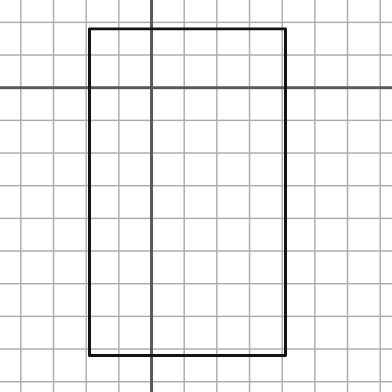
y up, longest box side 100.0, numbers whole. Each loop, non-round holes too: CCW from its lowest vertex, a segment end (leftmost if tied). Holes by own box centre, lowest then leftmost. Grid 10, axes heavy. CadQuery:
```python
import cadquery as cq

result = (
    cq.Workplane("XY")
    .moveTo(-19.0, -82.0)
    .lineTo(41.0, -82.0)
    .lineTo(41.0, 18.0)
    .lineTo(-19.0, 18.0)
    .close()
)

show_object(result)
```